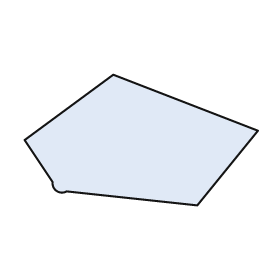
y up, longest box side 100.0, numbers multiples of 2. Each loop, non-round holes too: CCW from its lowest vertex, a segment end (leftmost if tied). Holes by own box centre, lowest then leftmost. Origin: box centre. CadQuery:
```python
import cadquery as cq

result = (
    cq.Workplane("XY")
    .moveTo(24.0, -28.0)
    .lineTo(50.0, 4.0)
    .lineTo(-12.0, 28.0)
    .lineTo(-50.0, 0.0)
    .lineTo(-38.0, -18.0)
    .threePointArc((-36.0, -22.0), (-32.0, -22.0))
    .close()
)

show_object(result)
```